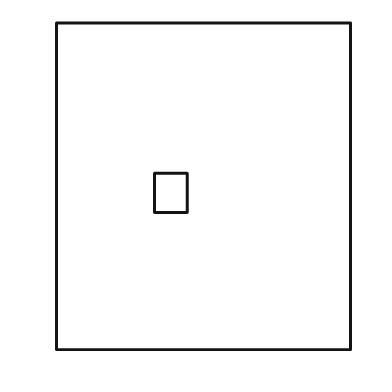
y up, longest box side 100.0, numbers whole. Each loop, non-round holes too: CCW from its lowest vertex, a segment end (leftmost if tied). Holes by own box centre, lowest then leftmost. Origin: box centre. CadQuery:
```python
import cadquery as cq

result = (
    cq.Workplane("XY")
    .moveTo(-45.0, -50.0)
    .lineTo(45.0, -50.0)
    .lineTo(45.0, 50.0)
    .lineTo(-45.0, 50.0)
    .close()
    .moveTo(-15.0, -8.0)
    .lineTo(-5.0, -8.0)
    .lineTo(-5.0, 4.0)
    .lineTo(-15.0, 4.0)
    .close()
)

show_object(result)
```